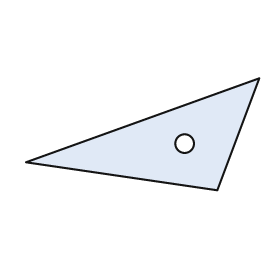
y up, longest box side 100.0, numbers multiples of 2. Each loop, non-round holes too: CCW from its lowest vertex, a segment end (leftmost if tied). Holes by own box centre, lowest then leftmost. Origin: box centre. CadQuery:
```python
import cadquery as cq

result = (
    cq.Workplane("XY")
    .moveTo(32.0, -24.0)
    .lineTo(50.0, 24.0)
    .lineTo(-50.0, -12.0)
    .close()
    .moveTo(18.0, -4.0)
    .circle(4.0)
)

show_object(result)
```